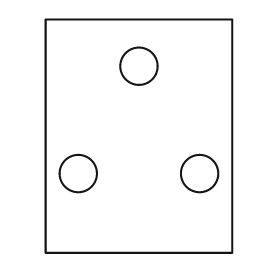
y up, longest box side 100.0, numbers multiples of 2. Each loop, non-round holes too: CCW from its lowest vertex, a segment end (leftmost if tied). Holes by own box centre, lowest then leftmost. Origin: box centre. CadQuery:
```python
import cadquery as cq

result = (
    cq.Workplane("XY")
    .moveTo(-40.0, -50.0)
    .lineTo(40.0, -50.0)
    .lineTo(40.0, 50.0)
    .lineTo(-40.0, 50.0)
    .close()
    .moveTo(-26.0, -16.0)
    .circle(8.0)
    .moveTo(26.0, -16.0)
    .circle(8.0)
    .moveTo(0.0, 30.0)
    .circle(8.0)
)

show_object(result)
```